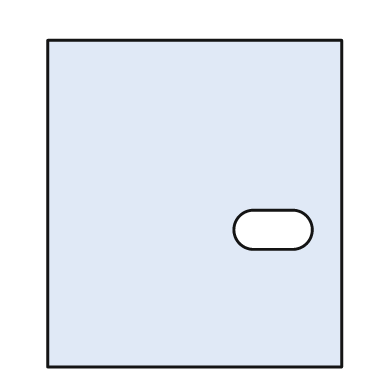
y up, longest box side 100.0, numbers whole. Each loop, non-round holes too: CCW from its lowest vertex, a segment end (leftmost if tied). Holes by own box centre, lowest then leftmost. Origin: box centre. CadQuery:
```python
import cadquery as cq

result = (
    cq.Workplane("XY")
    .moveTo(-45.0, -50.0)
    .lineTo(45.0, -50.0)
    .lineTo(45.0, 50.0)
    .lineTo(-45.0, 50.0)
    .close()
    .moveTo(18.0, -14.0)
    .lineTo(30.0, -14.0)
    .threePointArc((36.0, -8.0), (30.0, -2.0))
    .lineTo(18.0, -2.0)
    .threePointArc((12.0, -8.0), (18.0, -14.0))
    .close()
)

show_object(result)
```